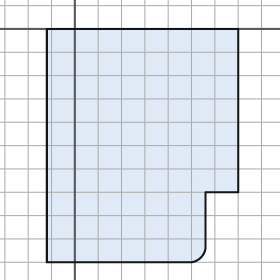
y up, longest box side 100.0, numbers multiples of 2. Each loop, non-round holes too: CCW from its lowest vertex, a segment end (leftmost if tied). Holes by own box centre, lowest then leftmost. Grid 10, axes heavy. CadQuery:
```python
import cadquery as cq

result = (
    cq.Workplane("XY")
    .moveTo(-12.0, -100.0)
    .lineTo(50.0, -100.0)
    .threePointArc((54.0, -98.0), (56.0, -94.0))
    .lineTo(56.0, -70.0)
    .lineTo(70.0, -70.0)
    .lineTo(70.0, 0.0)
    .lineTo(-12.0, 0.0)
    .close()
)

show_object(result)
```